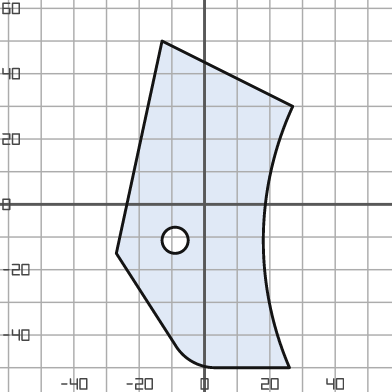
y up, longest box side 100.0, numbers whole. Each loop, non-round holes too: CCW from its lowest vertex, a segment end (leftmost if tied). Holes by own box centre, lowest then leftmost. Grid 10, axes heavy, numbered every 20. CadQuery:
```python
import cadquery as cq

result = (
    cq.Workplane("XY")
    .moveTo(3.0, -50.0)
    .lineTo(26.0, -50.0)
    .threePointArc((18.0, -10.0), (27.0, 30.0))
    .lineTo(-13.0, 50.0)
    .lineTo(-27.0, -15.0)
    .lineTo(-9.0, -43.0)
    .threePointArc((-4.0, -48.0), (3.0, -50.0))
    .close()
    .moveTo(-9.0, -11.0)
    .circle(4.0)
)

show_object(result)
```